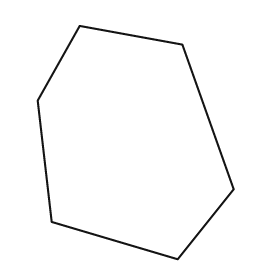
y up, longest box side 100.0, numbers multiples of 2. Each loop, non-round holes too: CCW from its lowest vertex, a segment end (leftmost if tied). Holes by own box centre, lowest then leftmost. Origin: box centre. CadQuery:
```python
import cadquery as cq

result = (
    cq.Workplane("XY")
    .moveTo(18.0, -50.0)
    .lineTo(42.0, -20.0)
    .lineTo(20.0, 42.0)
    .lineTo(-24.0, 50.0)
    .lineTo(-42.0, 18.0)
    .lineTo(-36.0, -34.0)
    .close()
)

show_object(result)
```